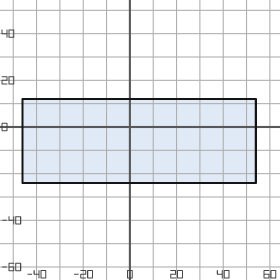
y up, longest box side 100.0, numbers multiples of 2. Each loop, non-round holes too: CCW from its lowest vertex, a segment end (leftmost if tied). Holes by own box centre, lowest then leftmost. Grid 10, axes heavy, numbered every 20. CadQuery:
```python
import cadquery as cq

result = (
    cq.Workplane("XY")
    .moveTo(-46.0, -24.0)
    .lineTo(54.0, -24.0)
    .lineTo(54.0, 12.0)
    .lineTo(-46.0, 12.0)
    .close()
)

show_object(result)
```